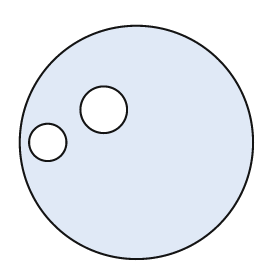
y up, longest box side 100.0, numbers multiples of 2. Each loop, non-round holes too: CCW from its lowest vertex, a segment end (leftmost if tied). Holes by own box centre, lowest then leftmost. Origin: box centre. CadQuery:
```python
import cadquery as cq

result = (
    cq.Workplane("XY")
    .moveTo(0.0, 0.0)
    .circle(50.0)
    .moveTo(-38.0, 0.0)
    .circle(8.0)
    .moveTo(-14.0, 14.0)
    .circle(10.0)
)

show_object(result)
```